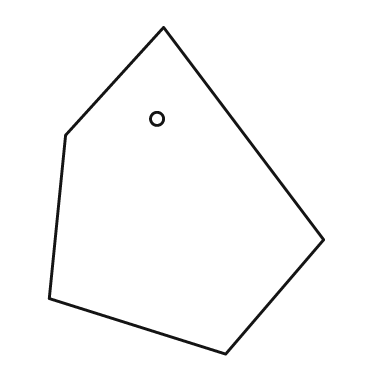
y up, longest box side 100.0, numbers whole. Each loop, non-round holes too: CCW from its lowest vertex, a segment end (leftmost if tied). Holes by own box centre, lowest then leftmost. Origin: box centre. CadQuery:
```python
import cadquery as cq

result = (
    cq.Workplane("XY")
    .moveTo(12.0, -50.0)
    .lineTo(42.0, -15.0)
    .lineTo(-7.0, 50.0)
    .lineTo(-37.0, 17.0)
    .lineTo(-42.0, -33.0)
    .close()
    .moveTo(-9.0, 22.0)
    .circle(2.0)
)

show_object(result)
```